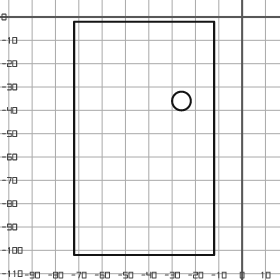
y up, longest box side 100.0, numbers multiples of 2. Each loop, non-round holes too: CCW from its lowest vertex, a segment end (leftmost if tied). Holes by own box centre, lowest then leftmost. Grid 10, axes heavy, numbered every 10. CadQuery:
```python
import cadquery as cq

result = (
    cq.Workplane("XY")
    .moveTo(-72.0, -102.0)
    .lineTo(-12.0, -102.0)
    .lineTo(-12.0, -2.0)
    .lineTo(-72.0, -2.0)
    .close()
    .moveTo(-26.0, -36.0)
    .circle(4.0)
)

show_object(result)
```